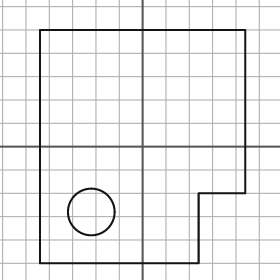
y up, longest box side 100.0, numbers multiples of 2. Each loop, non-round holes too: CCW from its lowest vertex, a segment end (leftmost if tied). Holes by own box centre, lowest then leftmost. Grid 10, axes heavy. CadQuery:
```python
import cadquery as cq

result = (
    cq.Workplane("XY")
    .moveTo(-44.0, -50.0)
    .lineTo(24.0, -50.0)
    .lineTo(24.0, -20.0)
    .lineTo(44.0, -20.0)
    .lineTo(44.0, 50.0)
    .lineTo(-44.0, 50.0)
    .close()
    .moveTo(-22.0, -28.0)
    .circle(10.0)
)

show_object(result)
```